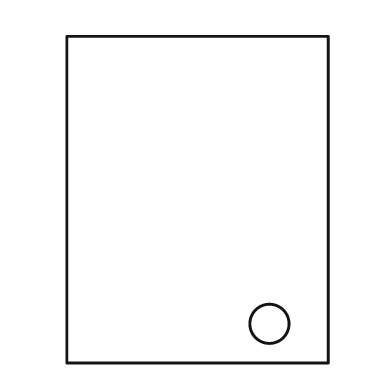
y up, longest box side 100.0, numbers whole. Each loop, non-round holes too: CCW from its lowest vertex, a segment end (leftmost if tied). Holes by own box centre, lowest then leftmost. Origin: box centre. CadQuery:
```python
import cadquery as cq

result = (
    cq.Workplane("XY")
    .moveTo(-40.0, -50.0)
    .lineTo(40.0, -50.0)
    .lineTo(40.0, 50.0)
    .lineTo(-40.0, 50.0)
    .close()
    .moveTo(22.0, -38.0)
    .circle(6.0)
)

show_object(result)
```